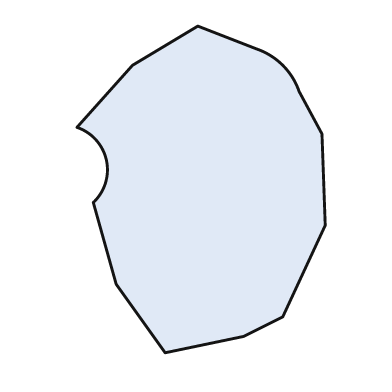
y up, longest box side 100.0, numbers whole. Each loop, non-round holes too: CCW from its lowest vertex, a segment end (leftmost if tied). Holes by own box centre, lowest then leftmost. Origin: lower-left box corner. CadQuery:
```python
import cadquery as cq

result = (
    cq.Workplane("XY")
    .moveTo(27.0, 0.0)
    .lineTo(51.0, 5.0)
    .lineTo(63.0, 11.0)
    .lineTo(76.0, 39.0)
    .lineTo(75.0, 67.0)
    .lineTo(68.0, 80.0)
    .threePointArc((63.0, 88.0), (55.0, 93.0))
    .lineTo(37.0, 100.0)
    .lineTo(17.0, 88.0)
    .lineTo(0.0, 69.0)
    .threePointArc((9.0, 59.0), (5.0, 46.0))
    .lineTo(12.0, 21.0)
    .close()
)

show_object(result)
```